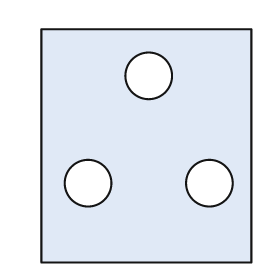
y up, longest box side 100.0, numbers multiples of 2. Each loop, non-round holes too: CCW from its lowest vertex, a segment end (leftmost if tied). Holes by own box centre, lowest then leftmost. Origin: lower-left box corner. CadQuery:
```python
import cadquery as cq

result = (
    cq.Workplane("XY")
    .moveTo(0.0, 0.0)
    .lineTo(90.0, 0.0)
    .lineTo(90.0, 100.0)
    .lineTo(0.0, 100.0)
    .close()
    .moveTo(20.0, 34.0)
    .circle(10.0)
    .moveTo(72.0, 34.0)
    .circle(10.0)
    .moveTo(46.0, 80.0)
    .circle(10.0)
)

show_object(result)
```